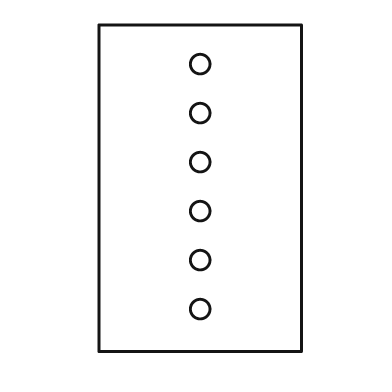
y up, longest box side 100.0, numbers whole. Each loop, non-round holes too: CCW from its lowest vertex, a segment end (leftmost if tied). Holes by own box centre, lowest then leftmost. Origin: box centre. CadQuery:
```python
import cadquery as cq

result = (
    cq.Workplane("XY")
    .moveTo(-31.0, -50.0)
    .lineTo(31.0, -50.0)
    .lineTo(31.0, 50.0)
    .lineTo(-31.0, 50.0)
    .close()
    .moveTo(0.0, -37.0)
    .circle(3.0)
    .moveTo(0.0, -22.0)
    .circle(3.0)
    .moveTo(0.0, -7.0)
    .circle(3.0)
    .moveTo(0.0, 8.0)
    .circle(3.0)
    .moveTo(0.0, 23.0)
    .circle(3.0)
    .moveTo(0.0, 38.0)
    .circle(3.0)
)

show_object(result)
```